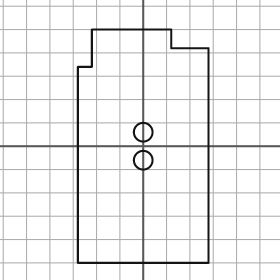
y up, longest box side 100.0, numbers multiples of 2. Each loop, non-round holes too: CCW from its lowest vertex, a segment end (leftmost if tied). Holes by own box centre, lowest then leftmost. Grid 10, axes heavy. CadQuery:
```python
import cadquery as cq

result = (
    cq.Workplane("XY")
    .moveTo(-28.0, -50.0)
    .lineTo(28.0, -50.0)
    .lineTo(28.0, 42.0)
    .lineTo(12.0, 42.0)
    .lineTo(12.0, 50.0)
    .lineTo(-22.0, 50.0)
    .lineTo(-22.0, 34.0)
    .lineTo(-28.0, 34.0)
    .close()
    .moveTo(0.0, -6.0)
    .circle(4.0)
    .moveTo(0.0, 6.0)
    .circle(4.0)
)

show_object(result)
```